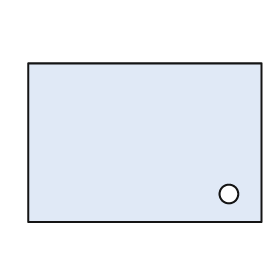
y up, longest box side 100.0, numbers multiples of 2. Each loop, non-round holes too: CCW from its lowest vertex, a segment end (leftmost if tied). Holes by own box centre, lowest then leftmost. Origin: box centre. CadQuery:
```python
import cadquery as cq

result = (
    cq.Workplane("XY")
    .moveTo(-50.0, -34.0)
    .lineTo(50.0, -34.0)
    .lineTo(50.0, 34.0)
    .lineTo(-50.0, 34.0)
    .close()
    .moveTo(36.0, -22.0)
    .circle(4.0)
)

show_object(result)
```